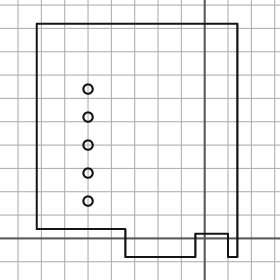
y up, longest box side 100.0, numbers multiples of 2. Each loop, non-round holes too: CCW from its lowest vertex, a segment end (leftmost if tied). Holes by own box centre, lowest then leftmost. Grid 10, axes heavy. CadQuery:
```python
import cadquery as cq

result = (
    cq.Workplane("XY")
    .moveTo(-34.0, -8.0)
    .lineTo(-4.0, -8.0)
    .lineTo(-4.0, 2.0)
    .lineTo(10.0, 2.0)
    .lineTo(10.0, -8.0)
    .lineTo(14.0, -8.0)
    .lineTo(14.0, 92.0)
    .lineTo(-72.0, 92.0)
    .lineTo(-72.0, 4.0)
    .lineTo(-34.0, 4.0)
    .close()
    .moveTo(-50.0, 16.0)
    .circle(2.0)
    .moveTo(-50.0, 28.0)
    .circle(2.0)
    .moveTo(-50.0, 40.0)
    .circle(2.0)
    .moveTo(-50.0, 52.0)
    .circle(2.0)
    .moveTo(-50.0, 64.0)
    .circle(2.0)
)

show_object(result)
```